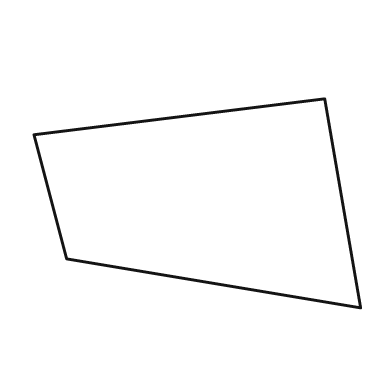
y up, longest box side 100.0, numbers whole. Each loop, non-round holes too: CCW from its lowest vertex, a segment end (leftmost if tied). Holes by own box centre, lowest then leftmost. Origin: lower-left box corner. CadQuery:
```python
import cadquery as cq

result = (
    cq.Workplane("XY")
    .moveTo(100.0, 0.0)
    .lineTo(89.0, 64.0)
    .lineTo(0.0, 53.0)
    .lineTo(10.0, 15.0)
    .close()
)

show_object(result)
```